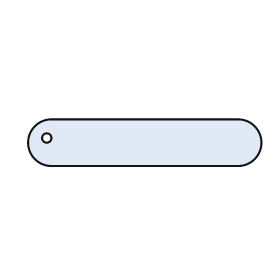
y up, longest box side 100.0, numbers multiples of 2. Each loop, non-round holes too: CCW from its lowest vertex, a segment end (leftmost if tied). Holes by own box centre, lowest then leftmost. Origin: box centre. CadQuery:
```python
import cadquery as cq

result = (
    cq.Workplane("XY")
    .moveTo(-40.0, -10.0)
    .lineTo(40.0, -10.0)
    .threePointArc((50.0, 0.0), (40.0, 10.0))
    .lineTo(-40.0, 10.0)
    .threePointArc((-50.0, 0.0), (-40.0, -10.0))
    .close()
    .moveTo(-42.0, 2.0)
    .circle(2.0)
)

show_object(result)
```